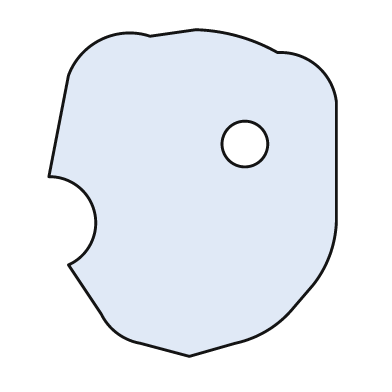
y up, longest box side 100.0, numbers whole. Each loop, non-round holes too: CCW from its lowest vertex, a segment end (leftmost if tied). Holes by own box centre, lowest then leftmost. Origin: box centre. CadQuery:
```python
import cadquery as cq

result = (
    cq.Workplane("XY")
    .moveTo(-1.0, -50.0)
    .lineTo(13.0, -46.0)
    .threePointArc((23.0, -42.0), (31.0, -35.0))
    .lineTo(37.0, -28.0)
    .threePointArc((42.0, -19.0), (44.0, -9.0))
    .lineTo(44.0, 28.0)
    .threePointArc((38.0, 39.0), (26.0, 43.0))
    .threePointArc((14.0, 48.0), (1.0, 50.0))
    .lineTo(-13.0, 48.0)
    .threePointArc((-28.0, 47.0), (-38.0, 36.0))
    .lineTo(-44.0, 5.0)
    .threePointArc((-30.0, -6.0), (-38.0, -22.0))
    .lineTo(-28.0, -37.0)
    .threePointArc((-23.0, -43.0), (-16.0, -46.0))
    .close()
    .moveTo(16.0, 15.0)
    .circle(7.0)
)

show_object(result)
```